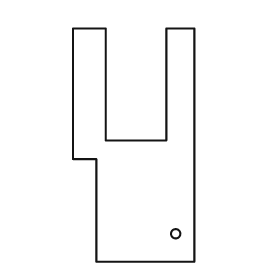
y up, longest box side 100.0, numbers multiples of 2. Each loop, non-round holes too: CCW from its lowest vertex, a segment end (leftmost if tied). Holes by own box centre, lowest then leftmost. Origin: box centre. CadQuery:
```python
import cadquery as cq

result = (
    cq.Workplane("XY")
    .moveTo(-16.0, -50.0)
    .lineTo(26.0, -50.0)
    .lineTo(26.0, 50.0)
    .lineTo(14.0, 50.0)
    .lineTo(14.0, 2.0)
    .lineTo(-12.0, 2.0)
    .lineTo(-12.0, 50.0)
    .lineTo(-26.0, 50.0)
    .lineTo(-26.0, -6.0)
    .lineTo(-16.0, -6.0)
    .close()
    .moveTo(18.0, -38.0)
    .circle(2.0)
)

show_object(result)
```